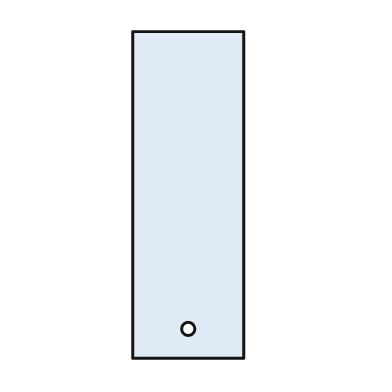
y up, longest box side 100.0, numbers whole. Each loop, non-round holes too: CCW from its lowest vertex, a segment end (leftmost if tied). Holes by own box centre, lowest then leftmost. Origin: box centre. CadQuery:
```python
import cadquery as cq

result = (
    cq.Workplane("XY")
    .moveTo(-17.0, -50.0)
    .lineTo(17.0, -50.0)
    .lineTo(17.0, 50.0)
    .lineTo(-17.0, 50.0)
    .close()
    .moveTo(0.0, -41.0)
    .circle(2.0)
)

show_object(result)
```